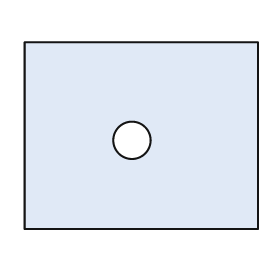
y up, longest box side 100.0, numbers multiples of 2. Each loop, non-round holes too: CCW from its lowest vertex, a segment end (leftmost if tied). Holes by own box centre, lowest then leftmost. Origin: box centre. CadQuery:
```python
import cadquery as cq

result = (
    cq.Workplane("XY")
    .moveTo(-50.0, -40.0)
    .lineTo(50.0, -40.0)
    .lineTo(50.0, 40.0)
    .lineTo(-50.0, 40.0)
    .close()
    .moveTo(-4.0, -2.0)
    .circle(8.0)
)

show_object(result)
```